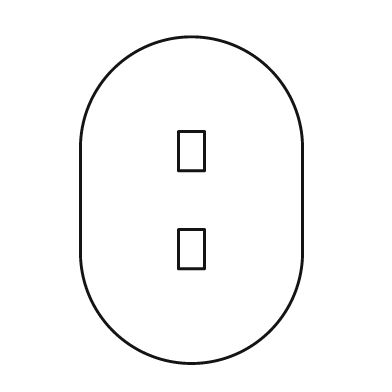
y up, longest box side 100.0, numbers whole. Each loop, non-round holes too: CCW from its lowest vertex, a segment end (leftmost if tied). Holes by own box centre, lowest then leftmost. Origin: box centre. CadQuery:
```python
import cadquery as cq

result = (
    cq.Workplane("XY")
    .moveTo(-34.0, -16.0)
    .threePointArc((0.0, -50.0), (34.0, -16.0))
    .lineTo(34.0, 16.0)
    .threePointArc((0.0, 50.0), (-34.0, 16.0))
    .close()
    .moveTo(-4.0, -21.0)
    .lineTo(4.0, -21.0)
    .lineTo(4.0, -9.0)
    .lineTo(-4.0, -9.0)
    .close()
    .moveTo(-4.0, 9.0)
    .lineTo(4.0, 9.0)
    .lineTo(4.0, 21.0)
    .lineTo(-4.0, 21.0)
    .close()
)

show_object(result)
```